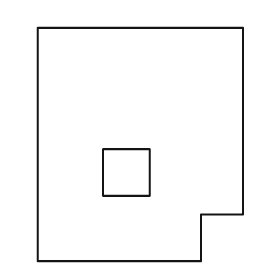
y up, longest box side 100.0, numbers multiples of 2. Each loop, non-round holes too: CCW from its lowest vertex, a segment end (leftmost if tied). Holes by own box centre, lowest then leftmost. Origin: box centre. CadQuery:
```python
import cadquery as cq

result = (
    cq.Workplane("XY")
    .moveTo(-44.0, -50.0)
    .lineTo(26.0, -50.0)
    .lineTo(26.0, -30.0)
    .lineTo(44.0, -30.0)
    .lineTo(44.0, 50.0)
    .lineTo(-44.0, 50.0)
    .close()
    .moveTo(-16.0, -22.0)
    .lineTo(4.0, -22.0)
    .lineTo(4.0, -2.0)
    .lineTo(-16.0, -2.0)
    .close()
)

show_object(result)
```